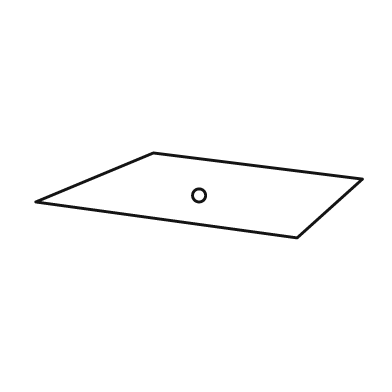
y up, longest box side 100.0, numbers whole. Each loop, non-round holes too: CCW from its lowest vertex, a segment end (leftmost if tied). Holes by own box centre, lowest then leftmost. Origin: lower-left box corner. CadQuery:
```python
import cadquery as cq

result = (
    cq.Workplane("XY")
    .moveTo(80.0, 0.0)
    .lineTo(100.0, 18.0)
    .lineTo(36.0, 26.0)
    .lineTo(0.0, 11.0)
    .close()
    .moveTo(50.0, 13.0)
    .circle(2.0)
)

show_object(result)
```